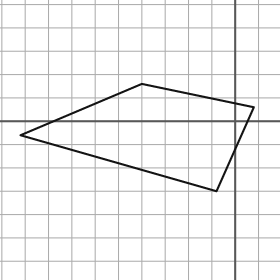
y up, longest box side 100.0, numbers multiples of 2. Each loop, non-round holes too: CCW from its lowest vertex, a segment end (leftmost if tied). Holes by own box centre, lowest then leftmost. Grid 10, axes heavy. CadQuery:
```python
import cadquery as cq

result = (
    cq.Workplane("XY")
    .moveTo(-8.0, -30.0)
    .lineTo(8.0, 6.0)
    .lineTo(-40.0, 16.0)
    .lineTo(-92.0, -6.0)
    .close()
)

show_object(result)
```